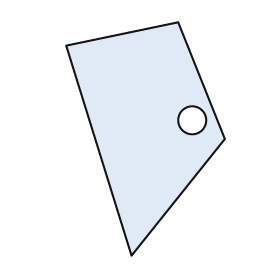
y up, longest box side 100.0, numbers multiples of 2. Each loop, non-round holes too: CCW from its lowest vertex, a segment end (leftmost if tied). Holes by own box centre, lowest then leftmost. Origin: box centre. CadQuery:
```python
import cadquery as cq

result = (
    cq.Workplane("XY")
    .moveTo(-6.0, -50.0)
    .lineTo(34.0, 0.0)
    .lineTo(14.0, 50.0)
    .lineTo(-34.0, 40.0)
    .close()
    .moveTo(20.0, 8.0)
    .circle(6.0)
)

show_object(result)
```